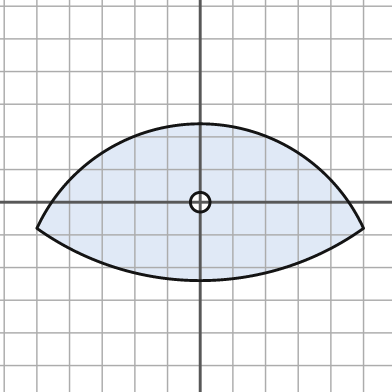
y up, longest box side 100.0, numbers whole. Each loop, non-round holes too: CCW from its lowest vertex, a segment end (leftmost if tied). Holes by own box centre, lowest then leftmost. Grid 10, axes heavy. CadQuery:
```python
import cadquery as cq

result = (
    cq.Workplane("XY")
    .moveTo(-50.0, -8.0)
    .threePointArc((0.0, -24.0), (50.0, -8.0))
    .threePointArc((0.0, 24.0), (-50.0, -8.0))
    .close()
    .moveTo(0.0, 0.0)
    .circle(3.0)
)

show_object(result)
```